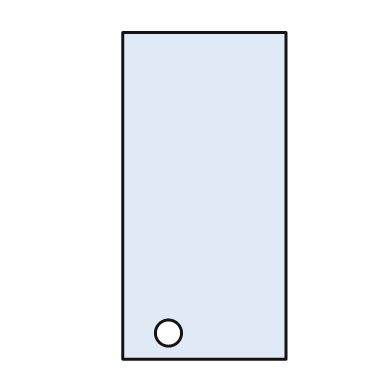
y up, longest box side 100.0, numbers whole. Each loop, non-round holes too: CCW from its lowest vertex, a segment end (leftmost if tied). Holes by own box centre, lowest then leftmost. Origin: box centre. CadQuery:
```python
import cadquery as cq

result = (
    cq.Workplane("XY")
    .moveTo(-25.0, -50.0)
    .lineTo(25.0, -50.0)
    .lineTo(25.0, 50.0)
    .lineTo(-25.0, 50.0)
    .close()
    .moveTo(-11.0, -42.0)
    .circle(4.0)
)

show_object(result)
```